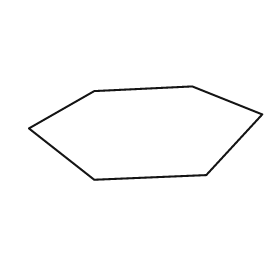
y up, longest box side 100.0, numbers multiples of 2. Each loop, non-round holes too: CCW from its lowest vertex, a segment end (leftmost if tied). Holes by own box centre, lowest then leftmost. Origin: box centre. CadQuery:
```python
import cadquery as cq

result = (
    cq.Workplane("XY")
    .moveTo(-22.0, -20.0)
    .lineTo(26.0, -18.0)
    .lineTo(50.0, 8.0)
    .lineTo(20.0, 20.0)
    .lineTo(-22.0, 18.0)
    .lineTo(-50.0, 2.0)
    .close()
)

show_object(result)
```